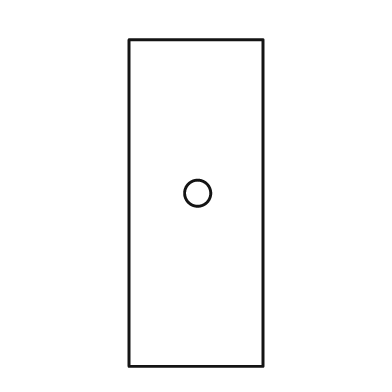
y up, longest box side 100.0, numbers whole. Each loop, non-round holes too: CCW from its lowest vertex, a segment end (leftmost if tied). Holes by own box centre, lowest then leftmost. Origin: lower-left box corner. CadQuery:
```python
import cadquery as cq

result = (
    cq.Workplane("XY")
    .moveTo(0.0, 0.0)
    .lineTo(41.0, 0.0)
    .lineTo(41.0, 100.0)
    .lineTo(0.0, 100.0)
    .close()
    .moveTo(21.0, 53.0)
    .circle(4.0)
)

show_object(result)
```